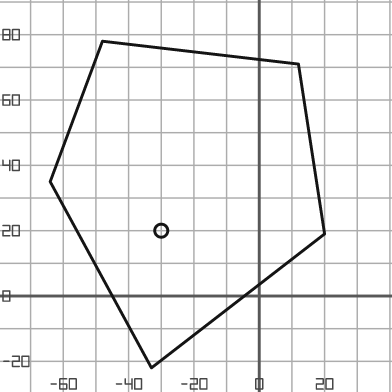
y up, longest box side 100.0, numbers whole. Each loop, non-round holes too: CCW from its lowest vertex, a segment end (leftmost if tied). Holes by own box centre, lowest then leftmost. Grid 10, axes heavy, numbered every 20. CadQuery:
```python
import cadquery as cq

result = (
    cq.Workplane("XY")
    .moveTo(-33.0, -22.0)
    .lineTo(20.0, 19.0)
    .lineTo(12.0, 71.0)
    .lineTo(-48.0, 78.0)
    .lineTo(-64.0, 35.0)
    .close()
    .moveTo(-30.0, 20.0)
    .circle(2.0)
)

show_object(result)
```